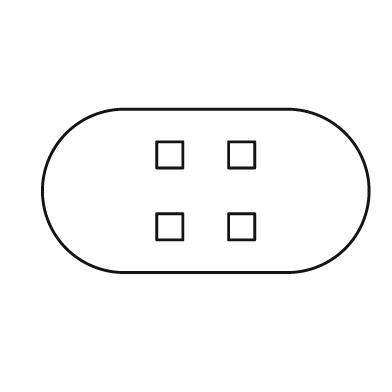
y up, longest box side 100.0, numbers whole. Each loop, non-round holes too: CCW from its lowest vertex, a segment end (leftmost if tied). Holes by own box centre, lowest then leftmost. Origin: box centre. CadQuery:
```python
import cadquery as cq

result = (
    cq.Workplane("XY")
    .moveTo(-25.0, -25.0)
    .lineTo(25.0, -25.0)
    .threePointArc((50.0, 0.0), (25.0, 25.0))
    .lineTo(-25.0, 25.0)
    .threePointArc((-50.0, 0.0), (-25.0, -25.0))
    .close()
    .moveTo(-15.0, -15.0)
    .lineTo(-7.0, -15.0)
    .lineTo(-7.0, -7.0)
    .lineTo(-15.0, -7.0)
    .close()
    .moveTo(7.0, -15.0)
    .lineTo(15.0, -15.0)
    .lineTo(15.0, -7.0)
    .lineTo(7.0, -7.0)
    .close()
    .moveTo(-15.0, 7.0)
    .lineTo(-7.0, 7.0)
    .lineTo(-7.0, 15.0)
    .lineTo(-15.0, 15.0)
    .close()
    .moveTo(7.0, 7.0)
    .lineTo(15.0, 7.0)
    .lineTo(15.0, 15.0)
    .lineTo(7.0, 15.0)
    .close()
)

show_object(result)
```